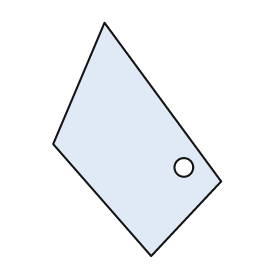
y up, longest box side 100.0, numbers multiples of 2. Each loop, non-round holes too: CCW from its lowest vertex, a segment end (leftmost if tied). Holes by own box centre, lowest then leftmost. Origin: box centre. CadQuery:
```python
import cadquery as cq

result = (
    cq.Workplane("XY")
    .moveTo(6.0, -50.0)
    .lineTo(36.0, -18.0)
    .lineTo(-14.0, 50.0)
    .lineTo(-36.0, -2.0)
    .close()
    .moveTo(20.0, -12.0)
    .circle(4.0)
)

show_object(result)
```